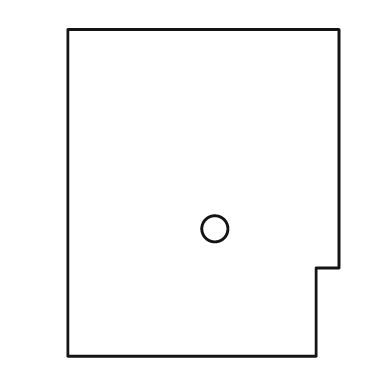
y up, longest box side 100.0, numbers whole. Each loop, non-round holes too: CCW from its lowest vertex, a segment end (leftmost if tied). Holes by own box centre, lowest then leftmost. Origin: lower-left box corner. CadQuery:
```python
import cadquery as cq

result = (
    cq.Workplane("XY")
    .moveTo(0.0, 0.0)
    .lineTo(76.0, 0.0)
    .lineTo(76.0, 27.0)
    .lineTo(83.0, 27.0)
    .lineTo(83.0, 100.0)
    .lineTo(0.0, 100.0)
    .close()
    .moveTo(45.0, 39.0)
    .circle(4.0)
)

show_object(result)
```